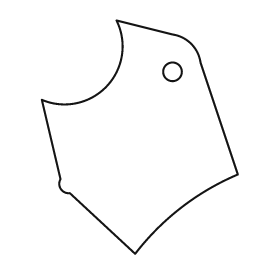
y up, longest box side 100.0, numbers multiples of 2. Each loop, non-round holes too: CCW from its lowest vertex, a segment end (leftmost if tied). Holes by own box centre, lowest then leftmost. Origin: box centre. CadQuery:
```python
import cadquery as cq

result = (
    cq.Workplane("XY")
    .moveTo(-2.0, -50.0)
    .threePointArc((18.0, -30.0), (42.0, -16.0))
    .lineTo(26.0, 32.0)
    .threePointArc((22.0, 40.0), (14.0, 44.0))
    .lineTo(-10.0, 50.0)
    .threePointArc((-14.0, 22.0), (-42.0, 16.0))
    .lineTo(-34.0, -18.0)
    .threePointArc((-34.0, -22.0), (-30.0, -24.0))
    .close()
    .moveTo(14.0, 28.0)
    .circle(4.0)
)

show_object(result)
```